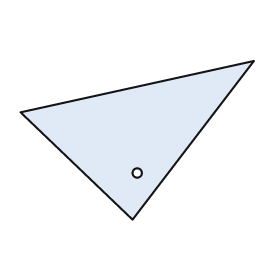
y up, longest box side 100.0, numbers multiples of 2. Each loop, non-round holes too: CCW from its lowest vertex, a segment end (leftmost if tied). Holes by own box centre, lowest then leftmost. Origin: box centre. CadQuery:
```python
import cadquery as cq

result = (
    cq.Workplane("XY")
    .moveTo(-2.0, -34.0)
    .lineTo(50.0, 34.0)
    .lineTo(-50.0, 12.0)
    .close()
    .moveTo(0.0, -14.0)
    .circle(2.0)
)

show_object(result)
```